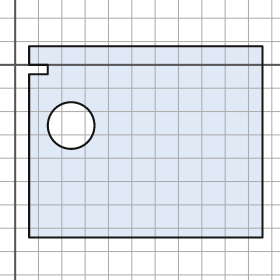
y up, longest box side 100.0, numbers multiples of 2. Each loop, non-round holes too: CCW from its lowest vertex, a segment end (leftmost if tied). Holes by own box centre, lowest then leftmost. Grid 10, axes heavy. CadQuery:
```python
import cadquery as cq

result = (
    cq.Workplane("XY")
    .moveTo(6.0, -74.0)
    .lineTo(106.0, -74.0)
    .lineTo(106.0, 8.0)
    .lineTo(6.0, 8.0)
    .lineTo(6.0, 0.0)
    .lineTo(14.0, 0.0)
    .lineTo(14.0, -4.0)
    .lineTo(6.0, -4.0)
    .close()
    .moveTo(24.0, -26.0)
    .circle(10.0)
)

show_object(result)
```